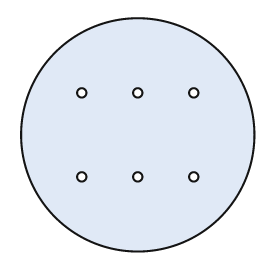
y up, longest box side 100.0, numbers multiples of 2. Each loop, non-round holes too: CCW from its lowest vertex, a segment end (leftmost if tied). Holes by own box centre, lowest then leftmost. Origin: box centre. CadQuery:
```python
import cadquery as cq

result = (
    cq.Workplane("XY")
    .moveTo(0.0, 0.0)
    .circle(50.0)
    .moveTo(-24.0, -18.0)
    .circle(2.0)
    .moveTo(0.0, -18.0)
    .circle(2.0)
    .moveTo(24.0, -18.0)
    .circle(2.0)
    .moveTo(-24.0, 18.0)
    .circle(2.0)
    .moveTo(0.0, 18.0)
    .circle(2.0)
    .moveTo(24.0, 18.0)
    .circle(2.0)
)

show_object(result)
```